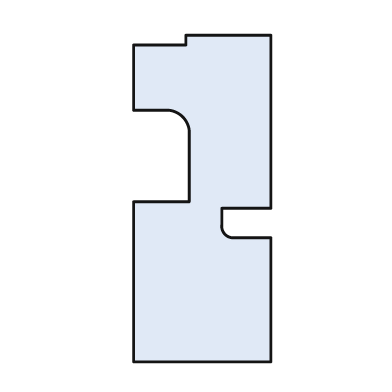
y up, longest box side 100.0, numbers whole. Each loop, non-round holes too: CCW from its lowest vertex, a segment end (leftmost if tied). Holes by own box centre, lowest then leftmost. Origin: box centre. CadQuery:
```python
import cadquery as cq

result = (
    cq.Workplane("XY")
    .moveTo(-21.0, -50.0)
    .lineTo(21.0, -50.0)
    .lineTo(21.0, -12.0)
    .lineTo(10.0, -12.0)
    .threePointArc((7.0, -11.0), (6.0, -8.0))
    .lineTo(6.0, -3.0)
    .lineTo(21.0, -3.0)
    .lineTo(21.0, 50.0)
    .lineTo(-5.0, 50.0)
    .lineTo(-5.0, 47.0)
    .lineTo(-21.0, 47.0)
    .lineTo(-21.0, 27.0)
    .lineTo(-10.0, 27.0)
    .threePointArc((-6.0, 25.0), (-4.0, 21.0))
    .lineTo(-4.0, -1.0)
    .lineTo(-21.0, -1.0)
    .close()
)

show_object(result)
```